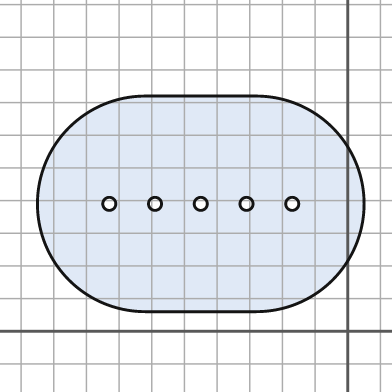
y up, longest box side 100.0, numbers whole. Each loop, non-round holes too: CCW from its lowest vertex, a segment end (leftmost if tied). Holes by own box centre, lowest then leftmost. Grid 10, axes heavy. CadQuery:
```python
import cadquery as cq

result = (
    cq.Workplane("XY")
    .moveTo(-62.0, 6.0)
    .lineTo(-28.0, 6.0)
    .threePointArc((5.0, 39.0), (-28.0, 72.0))
    .lineTo(-62.0, 72.0)
    .threePointArc((-95.0, 39.0), (-62.0, 6.0))
    .close()
    .moveTo(-73.0, 39.0)
    .circle(2.0)
    .moveTo(-59.0, 39.0)
    .circle(2.0)
    .moveTo(-45.0, 39.0)
    .circle(2.0)
    .moveTo(-31.0, 39.0)
    .circle(2.0)
    .moveTo(-17.0, 39.0)
    .circle(2.0)
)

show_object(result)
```